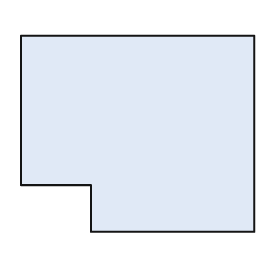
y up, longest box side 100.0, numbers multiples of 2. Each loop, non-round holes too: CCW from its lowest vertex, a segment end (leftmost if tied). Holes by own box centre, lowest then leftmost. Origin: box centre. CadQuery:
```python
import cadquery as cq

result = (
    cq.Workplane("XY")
    .moveTo(-20.0, -42.0)
    .lineTo(50.0, -42.0)
    .lineTo(50.0, 42.0)
    .lineTo(-50.0, 42.0)
    .lineTo(-50.0, -22.0)
    .lineTo(-20.0, -22.0)
    .close()
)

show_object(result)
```